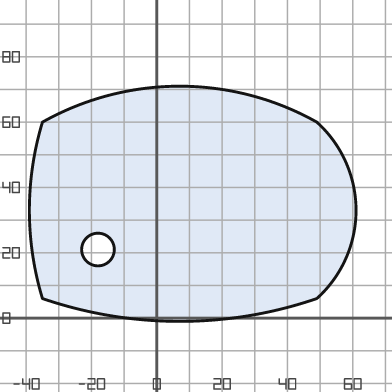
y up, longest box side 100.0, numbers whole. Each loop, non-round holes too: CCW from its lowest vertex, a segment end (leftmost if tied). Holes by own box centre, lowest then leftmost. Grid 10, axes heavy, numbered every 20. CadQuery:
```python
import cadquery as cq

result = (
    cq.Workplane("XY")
    .moveTo(-35.0, 6.0)
    .threePointArc((7.0, -1.0), (49.0, 6.0))
    .threePointArc((61.0, 33.0), (49.0, 60.0))
    .threePointArc((7.0, 71.0), (-35.0, 60.0))
    .threePointArc((-39.0, 33.0), (-35.0, 6.0))
    .close()
    .moveTo(-18.0, 21.0)
    .circle(5.0)
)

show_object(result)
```